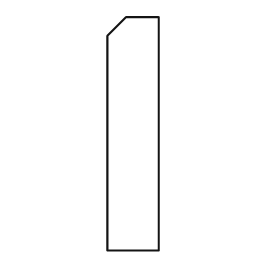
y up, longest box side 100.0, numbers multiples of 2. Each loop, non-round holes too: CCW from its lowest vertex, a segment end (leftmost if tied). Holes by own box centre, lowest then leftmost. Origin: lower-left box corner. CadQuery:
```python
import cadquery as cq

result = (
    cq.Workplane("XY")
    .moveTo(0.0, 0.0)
    .lineTo(22.0, 0.0)
    .lineTo(22.0, 100.0)
    .lineTo(8.0, 100.0)
    .lineTo(0.0, 92.0)
    .close()
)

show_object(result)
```